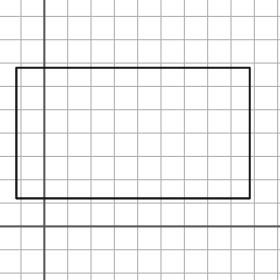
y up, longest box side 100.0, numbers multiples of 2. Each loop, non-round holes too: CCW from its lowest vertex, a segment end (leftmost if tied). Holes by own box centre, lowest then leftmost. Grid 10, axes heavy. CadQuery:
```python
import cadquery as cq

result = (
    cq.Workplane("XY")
    .moveTo(-12.0, 12.0)
    .lineTo(88.0, 12.0)
    .lineTo(88.0, 68.0)
    .lineTo(-12.0, 68.0)
    .close()
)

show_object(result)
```